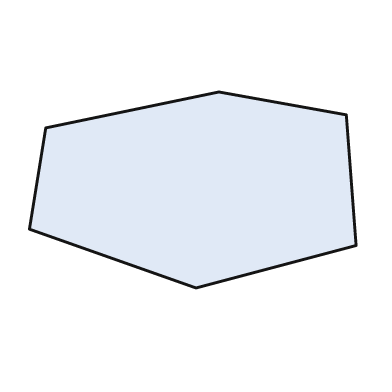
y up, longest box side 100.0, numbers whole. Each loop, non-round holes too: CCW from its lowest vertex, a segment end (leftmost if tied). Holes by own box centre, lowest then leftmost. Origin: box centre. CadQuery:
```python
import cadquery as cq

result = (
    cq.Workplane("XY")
    .moveTo(1.0, -30.0)
    .lineTo(50.0, -17.0)
    .lineTo(47.0, 23.0)
    .lineTo(8.0, 30.0)
    .lineTo(-45.0, 19.0)
    .lineTo(-50.0, -12.0)
    .close()
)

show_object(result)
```